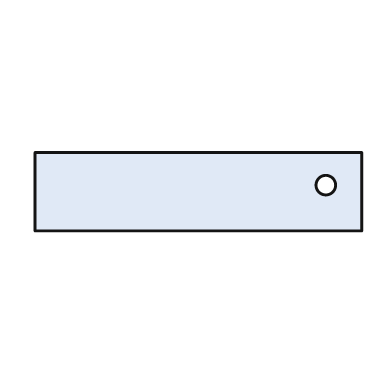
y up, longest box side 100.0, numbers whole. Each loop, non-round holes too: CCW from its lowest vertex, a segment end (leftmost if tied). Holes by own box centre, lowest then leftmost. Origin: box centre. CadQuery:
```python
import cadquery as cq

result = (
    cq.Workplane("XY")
    .moveTo(-50.0, -12.0)
    .lineTo(50.0, -12.0)
    .lineTo(50.0, 12.0)
    .lineTo(-50.0, 12.0)
    .close()
    .moveTo(39.0, 2.0)
    .circle(3.0)
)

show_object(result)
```